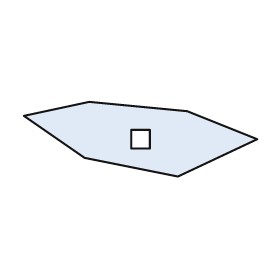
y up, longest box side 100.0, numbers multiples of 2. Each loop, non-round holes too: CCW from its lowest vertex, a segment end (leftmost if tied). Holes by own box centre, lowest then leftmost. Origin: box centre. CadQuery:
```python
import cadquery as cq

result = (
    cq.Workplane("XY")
    .moveTo(16.0, -16.0)
    .lineTo(50.0, 0.0)
    .lineTo(20.0, 12.0)
    .lineTo(-22.0, 16.0)
    .lineTo(-50.0, 10.0)
    .lineTo(-24.0, -8.0)
    .close()
    .moveTo(-4.0, -4.0)
    .lineTo(4.0, -4.0)
    .lineTo(4.0, 4.0)
    .lineTo(-4.0, 4.0)
    .close()
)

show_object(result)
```